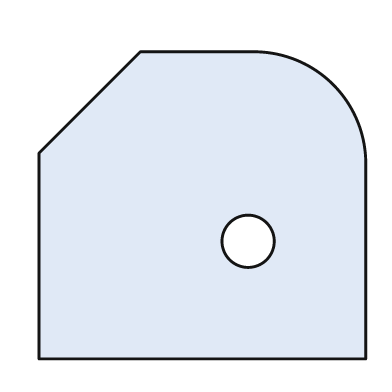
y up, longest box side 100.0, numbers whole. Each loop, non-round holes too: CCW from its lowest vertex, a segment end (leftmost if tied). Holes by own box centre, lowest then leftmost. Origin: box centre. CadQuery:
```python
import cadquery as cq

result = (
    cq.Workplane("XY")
    .moveTo(-50.0, -47.0)
    .lineTo(50.0, -47.0)
    .lineTo(50.0, 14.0)
    .threePointArc((40.0, 37.0), (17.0, 47.0))
    .lineTo(-19.0, 47.0)
    .lineTo(-50.0, 16.0)
    .close()
    .moveTo(14.0, -11.0)
    .circle(8.0)
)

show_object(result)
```